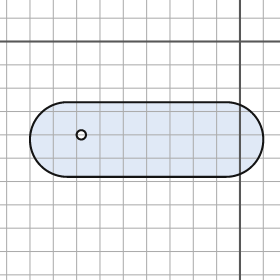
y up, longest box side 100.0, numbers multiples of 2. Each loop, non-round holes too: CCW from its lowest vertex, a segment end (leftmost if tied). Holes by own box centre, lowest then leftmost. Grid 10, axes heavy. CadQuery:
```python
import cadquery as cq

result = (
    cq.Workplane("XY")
    .moveTo(-74.0, -58.0)
    .lineTo(-6.0, -58.0)
    .threePointArc((10.0, -42.0), (-6.0, -26.0))
    .lineTo(-74.0, -26.0)
    .threePointArc((-90.0, -42.0), (-74.0, -58.0))
    .close()
    .moveTo(-68.0, -40.0)
    .circle(2.0)
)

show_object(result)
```